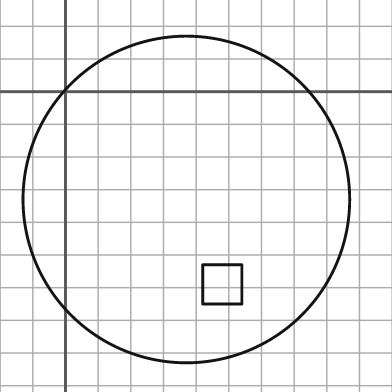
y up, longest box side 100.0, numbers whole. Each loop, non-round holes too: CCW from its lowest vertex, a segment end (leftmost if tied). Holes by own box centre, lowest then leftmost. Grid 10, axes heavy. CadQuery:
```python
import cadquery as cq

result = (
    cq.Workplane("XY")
    .moveTo(37.0, -33.0)
    .circle(50.0)
    .moveTo(42.0, -65.0)
    .lineTo(54.0, -65.0)
    .lineTo(54.0, -53.0)
    .lineTo(42.0, -53.0)
    .close()
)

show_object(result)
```